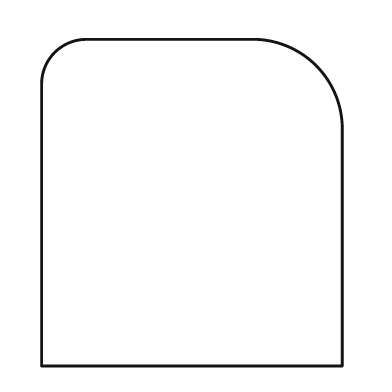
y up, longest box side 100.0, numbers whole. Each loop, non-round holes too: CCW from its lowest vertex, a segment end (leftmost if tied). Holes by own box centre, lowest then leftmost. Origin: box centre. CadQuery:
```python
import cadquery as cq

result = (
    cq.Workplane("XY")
    .moveTo(-46.0, -50.0)
    .lineTo(46.0, -50.0)
    .lineTo(46.0, 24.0)
    .threePointArc((38.0, 42.0), (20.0, 50.0))
    .lineTo(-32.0, 50.0)
    .threePointArc((-42.0, 46.0), (-46.0, 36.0))
    .close()
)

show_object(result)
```